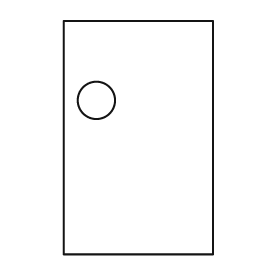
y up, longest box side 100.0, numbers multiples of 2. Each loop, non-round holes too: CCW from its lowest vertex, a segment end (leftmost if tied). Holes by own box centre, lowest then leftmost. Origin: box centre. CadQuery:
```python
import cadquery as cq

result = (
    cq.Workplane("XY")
    .moveTo(-32.0, -50.0)
    .lineTo(32.0, -50.0)
    .lineTo(32.0, 50.0)
    .lineTo(-32.0, 50.0)
    .close()
    .moveTo(-18.0, 16.0)
    .circle(8.0)
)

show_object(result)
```